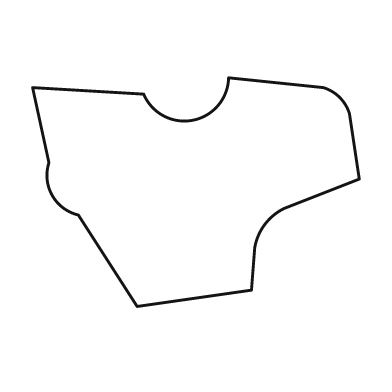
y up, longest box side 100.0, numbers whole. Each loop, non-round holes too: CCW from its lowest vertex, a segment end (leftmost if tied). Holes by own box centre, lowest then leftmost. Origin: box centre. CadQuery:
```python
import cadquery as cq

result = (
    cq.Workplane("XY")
    .moveTo(-18.0, -35.0)
    .lineTo(17.0, -30.0)
    .lineTo(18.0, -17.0)
    .threePointArc((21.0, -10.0), (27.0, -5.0))
    .lineTo(50.0, 4.0)
    .lineTo(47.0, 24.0)
    .threePointArc((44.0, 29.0), (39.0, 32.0))
    .lineTo(10.0, 35.0)
    .threePointArc((-1.0, 22.0), (-16.0, 30.0))
    .lineTo(-50.0, 32.0)
    .lineTo(-45.0, 9.0)
    .threePointArc((-44.0, -1.0), (-36.0, -7.0))
    .close()
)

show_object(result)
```